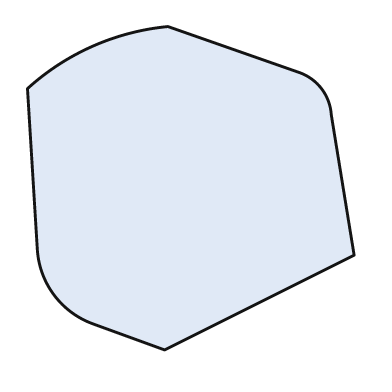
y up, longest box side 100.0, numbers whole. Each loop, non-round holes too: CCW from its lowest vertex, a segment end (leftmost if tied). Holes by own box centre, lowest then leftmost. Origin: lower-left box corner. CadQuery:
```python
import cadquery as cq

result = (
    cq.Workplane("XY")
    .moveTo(42.0, 0.0)
    .lineTo(100.0, 29.0)
    .lineTo(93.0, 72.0)
    .threePointArc((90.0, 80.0), (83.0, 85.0))
    .lineTo(43.0, 99.0)
    .threePointArc((20.0, 93.0), (0.0, 80.0))
    .lineTo(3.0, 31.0)
    .threePointArc((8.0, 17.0), (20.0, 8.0))
    .close()
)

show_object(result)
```